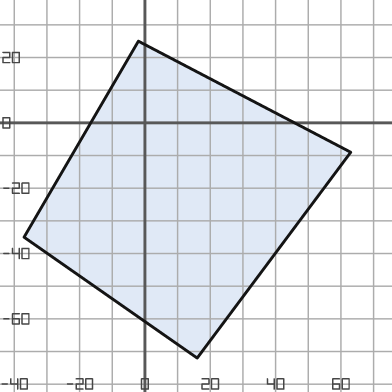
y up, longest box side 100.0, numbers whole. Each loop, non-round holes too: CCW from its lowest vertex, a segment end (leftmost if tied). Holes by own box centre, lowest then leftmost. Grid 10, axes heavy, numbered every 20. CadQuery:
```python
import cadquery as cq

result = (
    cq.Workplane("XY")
    .moveTo(16.0, -72.0)
    .lineTo(63.0, -9.0)
    .lineTo(-2.0, 25.0)
    .lineTo(-37.0, -35.0)
    .close()
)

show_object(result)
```